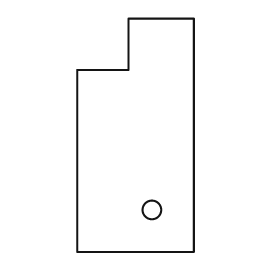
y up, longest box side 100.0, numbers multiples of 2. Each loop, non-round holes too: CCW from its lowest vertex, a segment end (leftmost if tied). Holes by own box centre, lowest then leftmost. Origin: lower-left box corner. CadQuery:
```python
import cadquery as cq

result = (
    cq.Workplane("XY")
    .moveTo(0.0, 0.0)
    .lineTo(50.0, 0.0)
    .lineTo(50.0, 100.0)
    .lineTo(22.0, 100.0)
    .lineTo(22.0, 78.0)
    .lineTo(0.0, 78.0)
    .close()
    .moveTo(32.0, 18.0)
    .circle(4.0)
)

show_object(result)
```